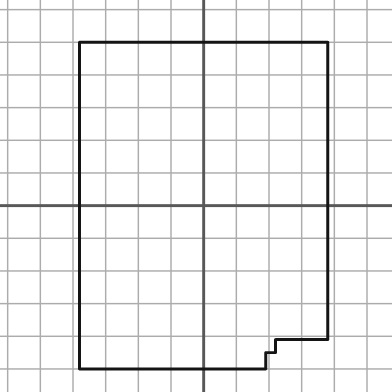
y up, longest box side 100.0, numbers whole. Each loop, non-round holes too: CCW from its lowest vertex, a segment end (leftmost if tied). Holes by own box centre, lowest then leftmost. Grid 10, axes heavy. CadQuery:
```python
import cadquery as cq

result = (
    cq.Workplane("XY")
    .moveTo(-38.0, -50.0)
    .lineTo(19.0, -50.0)
    .lineTo(19.0, -45.0)
    .lineTo(22.0, -45.0)
    .lineTo(22.0, -41.0)
    .lineTo(38.0, -41.0)
    .lineTo(38.0, 50.0)
    .lineTo(-38.0, 50.0)
    .close()
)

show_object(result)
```